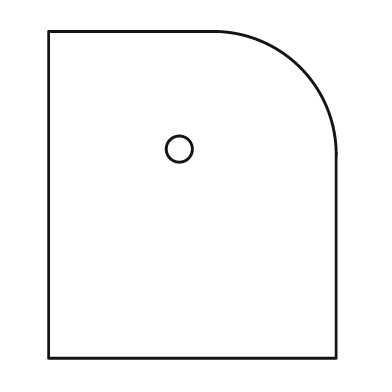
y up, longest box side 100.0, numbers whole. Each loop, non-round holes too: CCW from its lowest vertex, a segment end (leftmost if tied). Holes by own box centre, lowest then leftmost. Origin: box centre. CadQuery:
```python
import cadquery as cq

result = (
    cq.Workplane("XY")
    .moveTo(-44.0, -50.0)
    .lineTo(44.0, -50.0)
    .lineTo(44.0, 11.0)
    .threePointArc((33.0, 39.0), (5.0, 50.0))
    .lineTo(-44.0, 50.0)
    .close()
    .moveTo(-4.0, 14.0)
    .circle(4.0)
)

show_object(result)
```